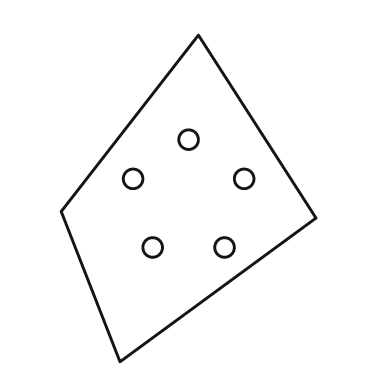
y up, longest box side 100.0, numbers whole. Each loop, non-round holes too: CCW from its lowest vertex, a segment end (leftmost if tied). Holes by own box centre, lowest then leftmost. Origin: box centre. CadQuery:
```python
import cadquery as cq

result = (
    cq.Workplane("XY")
    .moveTo(-21.0, -50.0)
    .lineTo(39.0, -6.0)
    .lineTo(3.0, 50.0)
    .lineTo(-39.0, -4.0)
    .close()
    .moveTo(-11.0, -15.0)
    .circle(3.0)
    .moveTo(11.0, -15.0)
    .circle(3.0)
    .moveTo(-17.0, 6.0)
    .circle(3.0)
    .moveTo(17.0, 6.0)
    .circle(3.0)
    .moveTo(0.0, 18.0)
    .circle(3.0)
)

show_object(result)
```